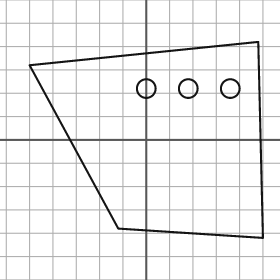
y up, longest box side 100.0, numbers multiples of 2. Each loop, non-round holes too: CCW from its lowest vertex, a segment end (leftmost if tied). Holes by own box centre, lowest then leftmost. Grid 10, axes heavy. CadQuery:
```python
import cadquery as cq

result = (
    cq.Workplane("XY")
    .moveTo(50.0, -42.0)
    .lineTo(48.0, 42.0)
    .lineTo(-50.0, 32.0)
    .lineTo(-12.0, -38.0)
    .close()
    .moveTo(0.0, 22.0)
    .circle(4.0)
    .moveTo(18.0, 22.0)
    .circle(4.0)
    .moveTo(36.0, 22.0)
    .circle(4.0)
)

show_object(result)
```